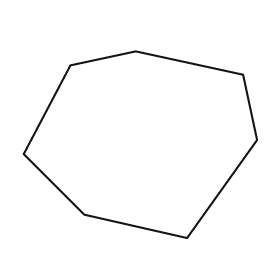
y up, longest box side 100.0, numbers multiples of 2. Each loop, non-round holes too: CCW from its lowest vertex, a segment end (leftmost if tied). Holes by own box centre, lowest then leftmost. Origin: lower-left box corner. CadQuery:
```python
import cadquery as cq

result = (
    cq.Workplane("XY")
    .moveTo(70.0, 0.0)
    .lineTo(100.0, 42.0)
    .lineTo(94.0, 70.0)
    .lineTo(48.0, 80.0)
    .lineTo(20.0, 74.0)
    .lineTo(0.0, 36.0)
    .lineTo(26.0, 10.0)
    .close()
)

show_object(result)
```